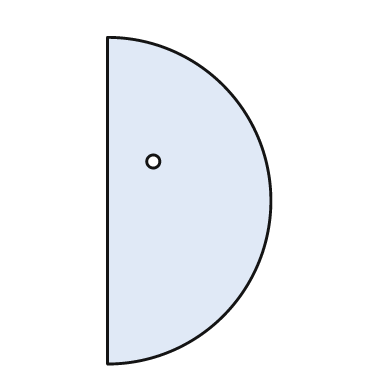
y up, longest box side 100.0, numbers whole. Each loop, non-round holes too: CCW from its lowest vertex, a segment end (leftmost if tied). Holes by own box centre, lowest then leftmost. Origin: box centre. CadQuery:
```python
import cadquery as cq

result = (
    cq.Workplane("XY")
    .moveTo(-25.0, -50.0)
    .threePointArc((25.0, 0.0), (-25.0, 50.0))
    .close()
    .moveTo(-11.0, 12.0)
    .circle(2.0)
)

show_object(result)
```